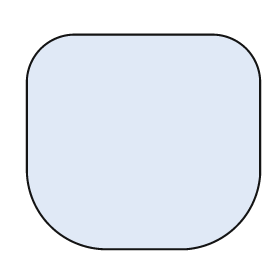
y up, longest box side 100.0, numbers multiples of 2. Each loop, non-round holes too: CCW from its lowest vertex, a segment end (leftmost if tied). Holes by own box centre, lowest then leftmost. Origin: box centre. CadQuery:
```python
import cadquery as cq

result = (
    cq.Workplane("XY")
    .moveTo(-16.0, -46.0)
    .lineTo(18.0, -46.0)
    .threePointArc((40.0, -36.0), (50.0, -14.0))
    .lineTo(50.0, 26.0)
    .threePointArc((44.0, 40.0), (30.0, 46.0))
    .lineTo(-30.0, 46.0)
    .threePointArc((-44.0, 40.0), (-50.0, 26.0))
    .lineTo(-50.0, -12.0)
    .threePointArc((-40.0, -36.0), (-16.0, -46.0))
    .close()
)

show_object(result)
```